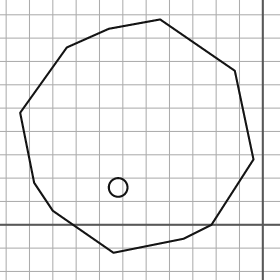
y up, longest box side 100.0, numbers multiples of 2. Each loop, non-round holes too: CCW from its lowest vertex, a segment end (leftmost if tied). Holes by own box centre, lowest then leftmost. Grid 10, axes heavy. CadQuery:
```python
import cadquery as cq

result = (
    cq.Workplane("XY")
    .moveTo(-64.0, -12.0)
    .lineTo(-34.0, -6.0)
    .lineTo(-22.0, 0.0)
    .lineTo(-4.0, 28.0)
    .lineTo(-12.0, 66.0)
    .lineTo(-44.0, 88.0)
    .lineTo(-66.0, 84.0)
    .lineTo(-84.0, 76.0)
    .lineTo(-104.0, 48.0)
    .lineTo(-98.0, 18.0)
    .lineTo(-90.0, 6.0)
    .close()
    .moveTo(-62.0, 16.0)
    .circle(4.0)
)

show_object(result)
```